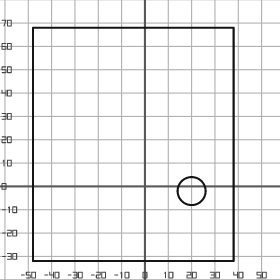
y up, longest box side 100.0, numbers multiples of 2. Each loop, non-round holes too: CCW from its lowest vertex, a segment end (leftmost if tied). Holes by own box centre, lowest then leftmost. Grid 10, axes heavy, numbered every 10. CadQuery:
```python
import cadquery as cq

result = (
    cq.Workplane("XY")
    .moveTo(-48.0, -32.0)
    .lineTo(38.0, -32.0)
    .lineTo(38.0, 68.0)
    .lineTo(-48.0, 68.0)
    .close()
    .moveTo(20.0, -2.0)
    .circle(6.0)
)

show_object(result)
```